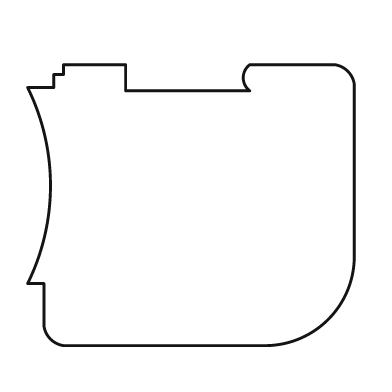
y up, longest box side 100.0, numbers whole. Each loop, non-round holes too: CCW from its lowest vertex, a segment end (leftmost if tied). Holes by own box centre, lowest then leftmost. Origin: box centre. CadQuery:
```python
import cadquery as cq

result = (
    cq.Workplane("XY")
    .moveTo(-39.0, -43.0)
    .lineTo(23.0, -43.0)
    .threePointArc((42.0, -35.0), (50.0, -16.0))
    .lineTo(50.0, 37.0)
    .threePointArc((48.0, 41.0), (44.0, 43.0))
    .lineTo(18.0, 43.0)
    .threePointArc((16.0, 39.0), (18.0, 35.0))
    .lineTo(-20.0, 35.0)
    .lineTo(-20.0, 43.0)
    .lineTo(-39.0, 43.0)
    .lineTo(-39.0, 40.0)
    .lineTo(-42.0, 40.0)
    .lineTo(-42.0, 36.0)
    .lineTo(-50.0, 36.0)
    .threePointArc((-43.0, 6.0), (-50.0, -24.0))
    .lineTo(-45.0, -24.0)
    .lineTo(-45.0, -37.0)
    .threePointArc((-43.0, -41.0), (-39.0, -43.0))
    .close()
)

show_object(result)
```